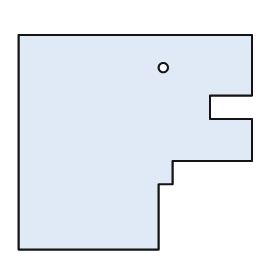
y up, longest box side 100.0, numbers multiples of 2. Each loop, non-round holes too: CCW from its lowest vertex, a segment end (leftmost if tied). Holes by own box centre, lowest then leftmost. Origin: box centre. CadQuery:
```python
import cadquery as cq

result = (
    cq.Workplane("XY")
    .moveTo(-50.0, -46.0)
    .lineTo(10.0, -46.0)
    .lineTo(10.0, -18.0)
    .lineTo(16.0, -18.0)
    .lineTo(16.0, -8.0)
    .lineTo(50.0, -8.0)
    .lineTo(50.0, 10.0)
    .lineTo(32.0, 10.0)
    .lineTo(32.0, 20.0)
    .lineTo(50.0, 20.0)
    .lineTo(50.0, 46.0)
    .lineTo(-50.0, 46.0)
    .close()
    .moveTo(12.0, 32.0)
    .circle(2.0)
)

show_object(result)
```